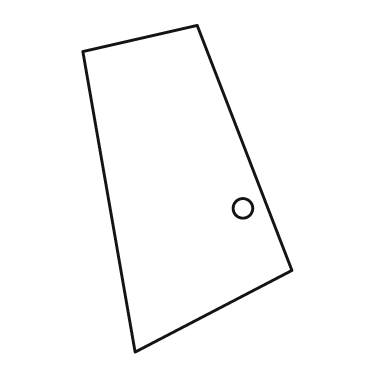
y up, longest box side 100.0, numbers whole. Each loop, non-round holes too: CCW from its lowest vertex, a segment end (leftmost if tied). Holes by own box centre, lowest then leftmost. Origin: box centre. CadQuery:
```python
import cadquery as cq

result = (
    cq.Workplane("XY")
    .moveTo(-16.0, -50.0)
    .lineTo(32.0, -25.0)
    .lineTo(3.0, 50.0)
    .lineTo(-32.0, 42.0)
    .close()
    .moveTo(17.0, -6.0)
    .circle(3.0)
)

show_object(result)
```